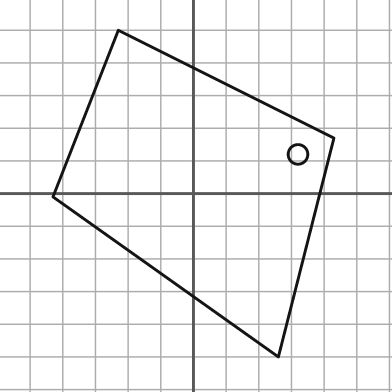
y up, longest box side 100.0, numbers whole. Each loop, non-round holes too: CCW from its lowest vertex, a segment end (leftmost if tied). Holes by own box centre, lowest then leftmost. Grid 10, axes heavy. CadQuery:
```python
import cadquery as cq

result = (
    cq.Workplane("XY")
    .moveTo(26.0, -50.0)
    .lineTo(43.0, 17.0)
    .lineTo(-23.0, 50.0)
    .lineTo(-43.0, -1.0)
    .close()
    .moveTo(32.0, 12.0)
    .circle(3.0)
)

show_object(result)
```